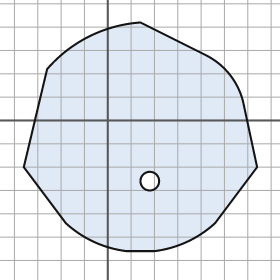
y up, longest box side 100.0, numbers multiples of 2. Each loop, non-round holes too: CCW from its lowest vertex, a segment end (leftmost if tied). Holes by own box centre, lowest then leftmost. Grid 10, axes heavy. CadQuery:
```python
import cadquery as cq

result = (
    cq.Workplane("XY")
    .moveTo(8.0, -56.0)
    .lineTo(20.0, -56.0)
    .threePointArc((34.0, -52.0), (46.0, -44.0))
    .lineTo(64.0, -20.0)
    .lineTo(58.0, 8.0)
    .threePointArc((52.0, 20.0), (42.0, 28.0))
    .lineTo(14.0, 42.0)
    .threePointArc((-8.0, 36.0), (-26.0, 22.0))
    .lineTo(-36.0, -20.0)
    .lineTo(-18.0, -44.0)
    .threePointArc((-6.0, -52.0), (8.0, -56.0))
    .close()
    .moveTo(18.0, -26.0)
    .circle(4.0)
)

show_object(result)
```